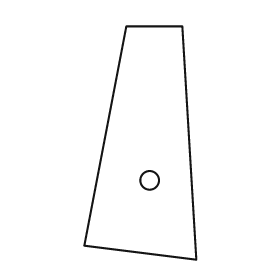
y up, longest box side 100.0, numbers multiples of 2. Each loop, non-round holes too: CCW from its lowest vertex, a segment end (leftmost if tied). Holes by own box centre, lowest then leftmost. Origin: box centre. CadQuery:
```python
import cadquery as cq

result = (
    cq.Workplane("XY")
    .moveTo(24.0, -50.0)
    .lineTo(18.0, 50.0)
    .lineTo(-6.0, 50.0)
    .lineTo(-24.0, -44.0)
    .close()
    .moveTo(4.0, -16.0)
    .circle(4.0)
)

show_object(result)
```